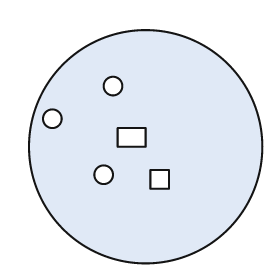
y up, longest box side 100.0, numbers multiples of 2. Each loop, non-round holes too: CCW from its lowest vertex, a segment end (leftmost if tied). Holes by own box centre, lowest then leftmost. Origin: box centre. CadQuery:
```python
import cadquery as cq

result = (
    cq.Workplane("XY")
    .moveTo(0.0, 0.0)
    .circle(50.0)
    .moveTo(2.0, -18.0)
    .lineTo(10.0, -18.0)
    .lineTo(10.0, -10.0)
    .lineTo(2.0, -10.0)
    .close()
    .moveTo(-18.0, -12.0)
    .circle(4.0)
    .moveTo(-12.0, 0.0)
    .lineTo(0.0, 0.0)
    .lineTo(0.0, 8.0)
    .lineTo(-12.0, 8.0)
    .close()
    .moveTo(-40.0, 12.0)
    .circle(4.0)
    .moveTo(-14.0, 26.0)
    .circle(4.0)
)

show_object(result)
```